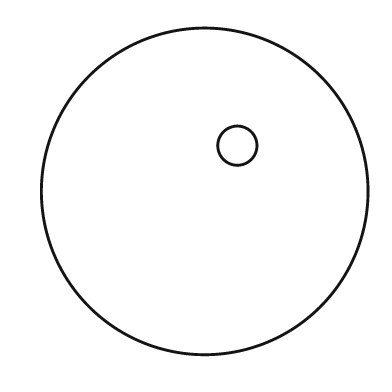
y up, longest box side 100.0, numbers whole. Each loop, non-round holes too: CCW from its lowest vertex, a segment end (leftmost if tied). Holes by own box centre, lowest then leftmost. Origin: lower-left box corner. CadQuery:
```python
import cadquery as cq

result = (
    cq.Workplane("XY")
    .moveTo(50.0, 50.0)
    .circle(50.0)
    .moveTo(60.0, 64.0)
    .circle(6.0)
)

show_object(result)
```